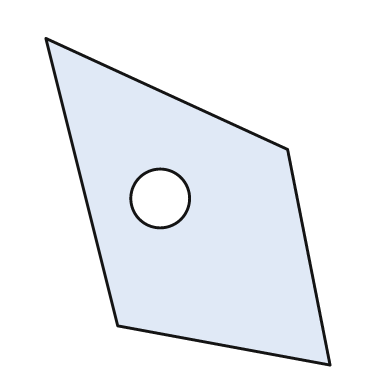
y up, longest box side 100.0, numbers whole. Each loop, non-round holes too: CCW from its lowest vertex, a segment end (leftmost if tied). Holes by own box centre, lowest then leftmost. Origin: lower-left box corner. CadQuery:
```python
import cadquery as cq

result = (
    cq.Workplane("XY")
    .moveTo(87.0, 0.0)
    .lineTo(74.0, 66.0)
    .lineTo(0.0, 100.0)
    .lineTo(22.0, 12.0)
    .close()
    .moveTo(35.0, 51.0)
    .circle(9.0)
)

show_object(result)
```